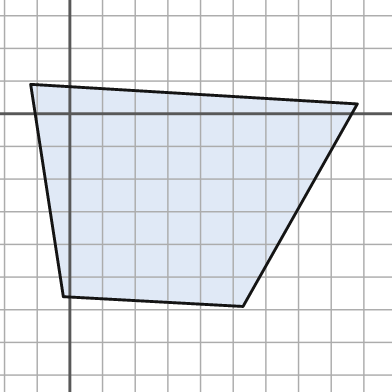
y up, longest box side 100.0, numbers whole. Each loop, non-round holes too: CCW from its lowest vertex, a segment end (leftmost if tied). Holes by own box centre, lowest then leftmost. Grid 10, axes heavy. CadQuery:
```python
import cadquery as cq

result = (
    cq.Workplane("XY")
    .moveTo(53.0, -59.0)
    .lineTo(88.0, 3.0)
    .lineTo(-12.0, 9.0)
    .lineTo(-2.0, -56.0)
    .close()
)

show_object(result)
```